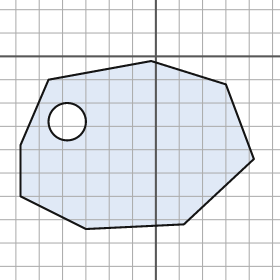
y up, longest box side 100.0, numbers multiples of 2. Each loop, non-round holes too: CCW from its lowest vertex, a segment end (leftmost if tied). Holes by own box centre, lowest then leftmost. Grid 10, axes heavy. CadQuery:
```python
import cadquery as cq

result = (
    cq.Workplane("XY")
    .moveTo(-30.0, -74.0)
    .lineTo(12.0, -72.0)
    .lineTo(42.0, -44.0)
    .lineTo(30.0, -12.0)
    .lineTo(-2.0, -2.0)
    .lineTo(-46.0, -10.0)
    .lineTo(-58.0, -38.0)
    .lineTo(-58.0, -60.0)
    .close()
    .moveTo(-38.0, -28.0)
    .circle(8.0)
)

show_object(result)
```